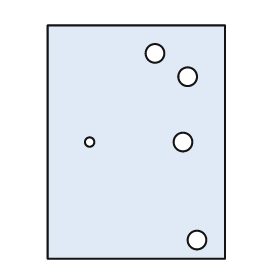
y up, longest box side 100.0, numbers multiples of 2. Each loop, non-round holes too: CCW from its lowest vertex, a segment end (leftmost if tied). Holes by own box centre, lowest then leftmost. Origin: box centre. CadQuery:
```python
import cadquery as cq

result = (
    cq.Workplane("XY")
    .moveTo(-38.0, -50.0)
    .lineTo(38.0, -50.0)
    .lineTo(38.0, 50.0)
    .lineTo(-38.0, 50.0)
    .close()
    .moveTo(26.0, -42.0)
    .circle(4.0)
    .moveTo(-20.0, 0.0)
    .circle(2.0)
    .moveTo(20.0, 0.0)
    .circle(4.0)
    .moveTo(22.0, 28.0)
    .circle(4.0)
    .moveTo(8.0, 38.0)
    .circle(4.0)
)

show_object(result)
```